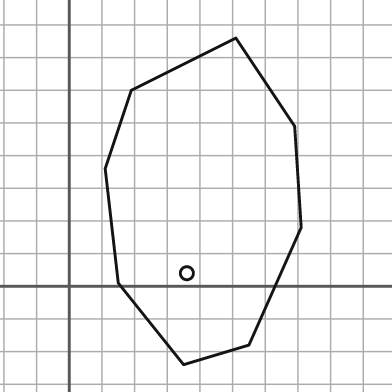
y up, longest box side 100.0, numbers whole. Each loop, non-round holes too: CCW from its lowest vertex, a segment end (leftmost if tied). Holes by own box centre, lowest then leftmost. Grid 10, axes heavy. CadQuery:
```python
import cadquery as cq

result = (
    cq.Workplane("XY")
    .moveTo(35.0, -24.0)
    .lineTo(55.0, -18.0)
    .lineTo(71.0, 18.0)
    .lineTo(69.0, 49.0)
    .lineTo(51.0, 76.0)
    .lineTo(19.0, 60.0)
    .lineTo(11.0, 36.0)
    .lineTo(15.0, 1.0)
    .close()
    .moveTo(36.0, 4.0)
    .circle(2.0)
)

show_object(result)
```